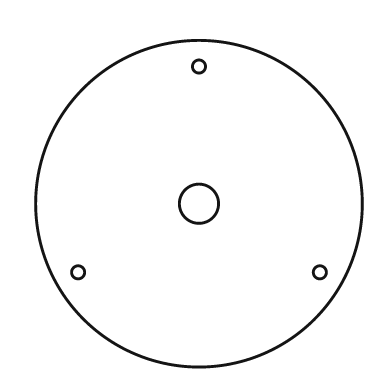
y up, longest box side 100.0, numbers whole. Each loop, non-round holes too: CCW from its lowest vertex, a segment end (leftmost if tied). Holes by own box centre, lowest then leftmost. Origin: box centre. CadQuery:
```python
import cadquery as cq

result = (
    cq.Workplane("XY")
    .moveTo(0.0, 0.0)
    .circle(50.0)
    .moveTo(-37.0, -21.0)
    .circle(2.0)
    .moveTo(37.0, -21.0)
    .circle(2.0)
    .moveTo(0.0, 0.0)
    .circle(6.0)
    .moveTo(0.0, 42.0)
    .circle(2.0)
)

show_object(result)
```